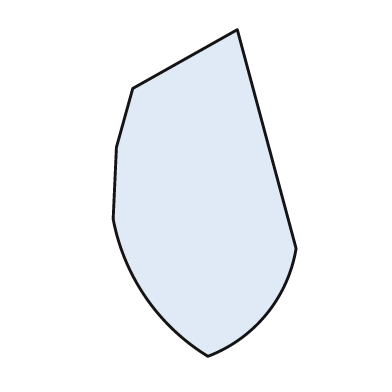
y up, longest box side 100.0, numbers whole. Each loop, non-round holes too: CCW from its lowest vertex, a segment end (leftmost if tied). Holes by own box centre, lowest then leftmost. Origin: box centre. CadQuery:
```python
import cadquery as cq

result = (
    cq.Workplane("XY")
    .moveTo(1.0, -50.0)
    .threePointArc((19.0, -37.0), (28.0, -17.0))
    .lineTo(10.0, 50.0)
    .lineTo(-22.0, 32.0)
    .lineTo(-27.0, 14.0)
    .lineTo(-28.0, -8.0)
    .threePointArc((-18.0, -32.0), (1.0, -50.0))
    .close()
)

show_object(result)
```